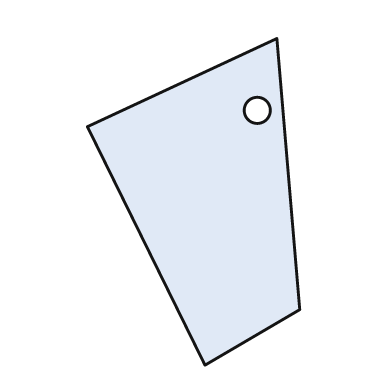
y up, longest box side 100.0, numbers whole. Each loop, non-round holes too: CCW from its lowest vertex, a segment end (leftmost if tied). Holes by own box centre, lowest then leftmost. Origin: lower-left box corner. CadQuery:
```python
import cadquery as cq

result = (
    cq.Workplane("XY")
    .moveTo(36.0, 0.0)
    .lineTo(65.0, 17.0)
    .lineTo(58.0, 100.0)
    .lineTo(0.0, 73.0)
    .close()
    .moveTo(52.0, 78.0)
    .circle(4.0)
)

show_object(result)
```